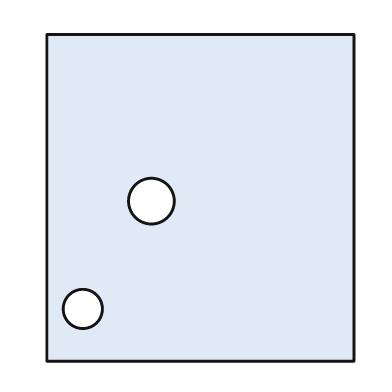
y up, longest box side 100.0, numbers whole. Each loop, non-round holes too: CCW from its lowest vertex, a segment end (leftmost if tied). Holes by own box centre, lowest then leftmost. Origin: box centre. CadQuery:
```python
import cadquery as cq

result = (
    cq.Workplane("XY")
    .moveTo(-47.0, -50.0)
    .lineTo(47.0, -50.0)
    .lineTo(47.0, 50.0)
    .lineTo(-47.0, 50.0)
    .close()
    .moveTo(-36.0, -34.0)
    .circle(6.0)
    .moveTo(-15.0, -1.0)
    .circle(7.0)
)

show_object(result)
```